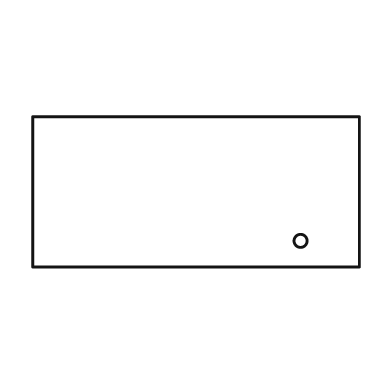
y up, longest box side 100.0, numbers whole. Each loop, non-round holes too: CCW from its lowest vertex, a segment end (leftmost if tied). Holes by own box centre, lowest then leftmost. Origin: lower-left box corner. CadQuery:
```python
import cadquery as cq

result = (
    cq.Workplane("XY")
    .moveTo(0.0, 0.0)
    .lineTo(100.0, 0.0)
    .lineTo(100.0, 46.0)
    .lineTo(0.0, 46.0)
    .close()
    .moveTo(82.0, 8.0)
    .circle(2.0)
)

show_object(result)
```